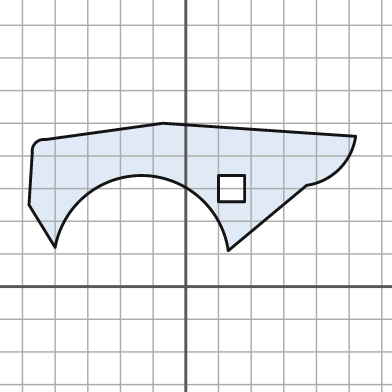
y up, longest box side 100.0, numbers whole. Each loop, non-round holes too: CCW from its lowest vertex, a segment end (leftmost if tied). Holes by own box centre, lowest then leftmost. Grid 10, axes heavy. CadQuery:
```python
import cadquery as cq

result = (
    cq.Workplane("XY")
    .moveTo(13.0, 11.0)
    .lineTo(37.0, 31.0)
    .threePointArc((47.0, 36.0), (52.0, 46.0))
    .lineTo(-7.0, 50.0)
    .lineTo(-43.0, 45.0)
    .threePointArc((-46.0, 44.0), (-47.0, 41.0))
    .lineTo(-48.0, 25.0)
    .lineTo(-40.0, 12.0)
    .threePointArc((-13.0, 34.0), (13.0, 11.0))
    .close()
    .moveTo(10.0, 26.0)
    .lineTo(18.0, 26.0)
    .lineTo(18.0, 34.0)
    .lineTo(10.0, 34.0)
    .close()
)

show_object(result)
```